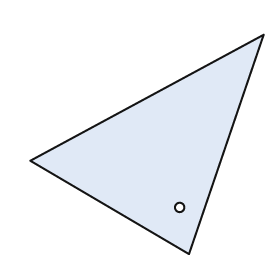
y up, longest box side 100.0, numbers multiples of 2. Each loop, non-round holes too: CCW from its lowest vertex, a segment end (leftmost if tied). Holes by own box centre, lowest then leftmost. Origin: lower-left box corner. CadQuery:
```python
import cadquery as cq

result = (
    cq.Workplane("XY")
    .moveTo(68.0, 0.0)
    .lineTo(100.0, 94.0)
    .lineTo(0.0, 40.0)
    .close()
    .moveTo(64.0, 20.0)
    .circle(2.0)
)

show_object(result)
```